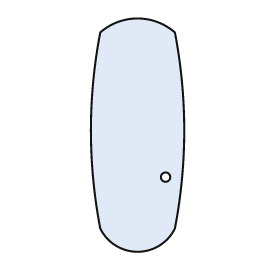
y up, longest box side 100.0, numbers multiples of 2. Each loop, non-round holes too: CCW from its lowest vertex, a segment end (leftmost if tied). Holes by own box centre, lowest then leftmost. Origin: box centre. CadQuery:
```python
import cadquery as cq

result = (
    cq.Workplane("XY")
    .moveTo(-16.0, -40.0)
    .threePointArc((0.0, -50.0), (16.0, -40.0))
    .threePointArc((20.0, 2.0), (16.0, 44.0))
    .threePointArc((0.0, 50.0), (-16.0, 44.0))
    .threePointArc((-20.0, 2.0), (-16.0, -40.0))
    .close()
    .moveTo(12.0, -18.0)
    .circle(2.0)
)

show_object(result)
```